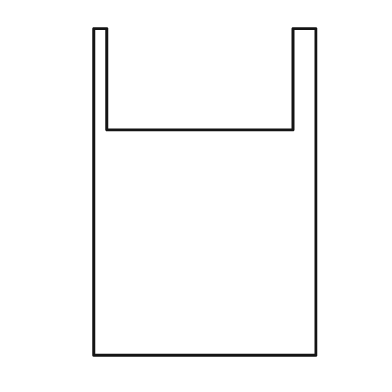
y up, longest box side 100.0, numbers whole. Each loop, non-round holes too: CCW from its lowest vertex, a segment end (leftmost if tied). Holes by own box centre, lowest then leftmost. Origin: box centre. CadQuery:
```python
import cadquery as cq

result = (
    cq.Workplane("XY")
    .moveTo(-34.0, -50.0)
    .lineTo(34.0, -50.0)
    .lineTo(34.0, 50.0)
    .lineTo(27.0, 50.0)
    .lineTo(27.0, 19.0)
    .lineTo(-30.0, 19.0)
    .lineTo(-30.0, 50.0)
    .lineTo(-34.0, 50.0)
    .close()
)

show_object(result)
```